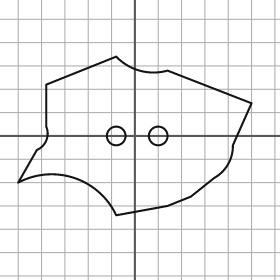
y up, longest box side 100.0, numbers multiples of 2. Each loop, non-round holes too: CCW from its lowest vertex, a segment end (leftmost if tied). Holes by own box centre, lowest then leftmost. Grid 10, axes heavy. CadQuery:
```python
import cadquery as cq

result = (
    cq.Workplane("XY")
    .moveTo(-8.0, -34.0)
    .lineTo(14.0, -30.0)
    .lineTo(24.0, -26.0)
    .lineTo(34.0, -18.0)
    .threePointArc((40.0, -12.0), (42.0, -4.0))
    .lineTo(50.0, 14.0)
    .lineTo(14.0, 28.0)
    .threePointArc((2.0, 28.0), (-8.0, 34.0))
    .lineTo(-38.0, 22.0)
    .lineTo(-38.0, 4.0)
    .threePointArc((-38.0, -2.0), (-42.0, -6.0))
    .lineTo(-50.0, -20.0)
    .threePointArc((-26.0, -18.0), (-8.0, -34.0))
    .close()
    .moveTo(-8.0, 0.0)
    .circle(4.0)
    .moveTo(10.0, 0.0)
    .circle(4.0)
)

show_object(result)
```